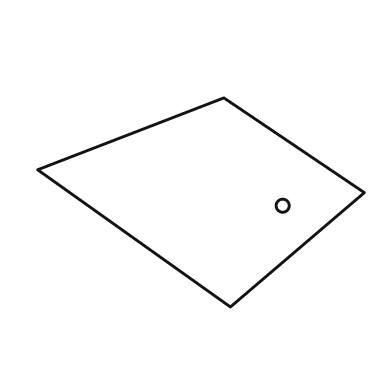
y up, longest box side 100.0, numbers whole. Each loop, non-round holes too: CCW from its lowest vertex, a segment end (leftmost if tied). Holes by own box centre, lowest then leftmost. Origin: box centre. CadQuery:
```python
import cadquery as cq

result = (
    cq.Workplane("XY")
    .moveTo(9.0, -32.0)
    .lineTo(50.0, 3.0)
    .lineTo(7.0, 32.0)
    .lineTo(-50.0, 10.0)
    .close()
    .moveTo(25.0, -1.0)
    .circle(2.0)
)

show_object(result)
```